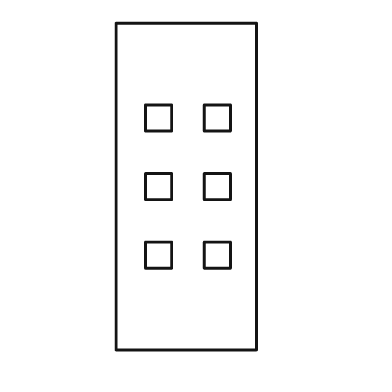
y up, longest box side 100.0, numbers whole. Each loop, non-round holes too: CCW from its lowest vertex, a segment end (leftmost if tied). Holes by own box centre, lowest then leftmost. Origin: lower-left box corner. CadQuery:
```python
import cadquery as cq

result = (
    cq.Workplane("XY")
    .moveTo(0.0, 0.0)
    .lineTo(43.0, 0.0)
    .lineTo(43.0, 100.0)
    .lineTo(0.0, 100.0)
    .close()
    .moveTo(9.0, 25.0)
    .lineTo(17.0, 25.0)
    .lineTo(17.0, 33.0)
    .lineTo(9.0, 33.0)
    .close()
    .moveTo(27.0, 25.0)
    .lineTo(35.0, 25.0)
    .lineTo(35.0, 33.0)
    .lineTo(27.0, 33.0)
    .close()
    .moveTo(9.0, 46.0)
    .lineTo(17.0, 46.0)
    .lineTo(17.0, 54.0)
    .lineTo(9.0, 54.0)
    .close()
    .moveTo(27.0, 46.0)
    .lineTo(35.0, 46.0)
    .lineTo(35.0, 54.0)
    .lineTo(27.0, 54.0)
    .close()
    .moveTo(9.0, 67.0)
    .lineTo(17.0, 67.0)
    .lineTo(17.0, 75.0)
    .lineTo(9.0, 75.0)
    .close()
    .moveTo(27.0, 67.0)
    .lineTo(35.0, 67.0)
    .lineTo(35.0, 75.0)
    .lineTo(27.0, 75.0)
    .close()
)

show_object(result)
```